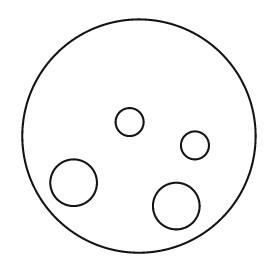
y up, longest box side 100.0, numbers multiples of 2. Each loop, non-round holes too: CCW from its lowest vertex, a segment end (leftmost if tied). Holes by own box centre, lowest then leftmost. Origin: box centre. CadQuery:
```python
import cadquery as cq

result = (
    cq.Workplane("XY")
    .moveTo(0.0, 0.0)
    .circle(50.0)
    .moveTo(16.0, -30.0)
    .circle(10.0)
    .moveTo(-28.0, -20.0)
    .circle(10.0)
    .moveTo(24.0, -4.0)
    .circle(6.0)
    .moveTo(-4.0, 6.0)
    .circle(6.0)
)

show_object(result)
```